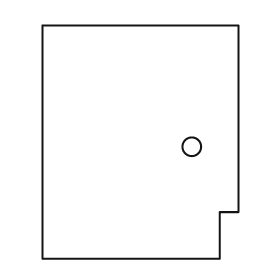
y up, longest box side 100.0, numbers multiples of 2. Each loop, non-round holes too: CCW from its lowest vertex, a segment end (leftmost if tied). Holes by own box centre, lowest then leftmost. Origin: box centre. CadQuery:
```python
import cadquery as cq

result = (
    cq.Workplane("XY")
    .moveTo(-42.0, -50.0)
    .lineTo(34.0, -50.0)
    .lineTo(34.0, -30.0)
    .lineTo(42.0, -30.0)
    .lineTo(42.0, 50.0)
    .lineTo(-42.0, 50.0)
    .close()
    .moveTo(22.0, -2.0)
    .circle(4.0)
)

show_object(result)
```